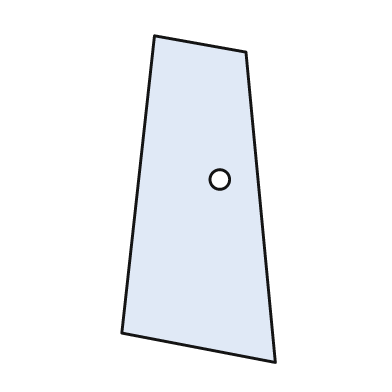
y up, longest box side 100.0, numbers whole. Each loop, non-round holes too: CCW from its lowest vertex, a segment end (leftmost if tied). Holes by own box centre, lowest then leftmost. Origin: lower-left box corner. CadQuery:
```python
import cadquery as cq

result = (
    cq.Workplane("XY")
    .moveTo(47.0, 0.0)
    .lineTo(38.0, 95.0)
    .lineTo(10.0, 100.0)
    .lineTo(0.0, 9.0)
    .close()
    .moveTo(30.0, 56.0)
    .circle(3.0)
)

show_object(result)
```